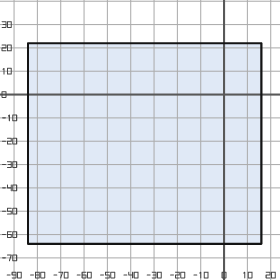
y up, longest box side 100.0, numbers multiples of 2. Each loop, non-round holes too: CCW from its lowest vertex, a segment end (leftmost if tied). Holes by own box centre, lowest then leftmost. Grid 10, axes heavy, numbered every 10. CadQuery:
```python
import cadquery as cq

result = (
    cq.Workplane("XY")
    .moveTo(-84.0, -64.0)
    .lineTo(16.0, -64.0)
    .lineTo(16.0, 22.0)
    .lineTo(-84.0, 22.0)
    .close()
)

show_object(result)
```